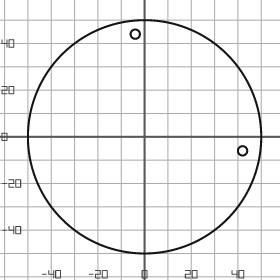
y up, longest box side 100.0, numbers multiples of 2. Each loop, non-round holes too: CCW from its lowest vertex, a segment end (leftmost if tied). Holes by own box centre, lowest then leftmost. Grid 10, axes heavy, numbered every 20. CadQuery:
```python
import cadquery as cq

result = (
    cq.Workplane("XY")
    .moveTo(0.0, 0.0)
    .circle(50.0)
    .moveTo(42.0, -6.0)
    .circle(2.0)
    .moveTo(-4.0, 44.0)
    .circle(2.0)
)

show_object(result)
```